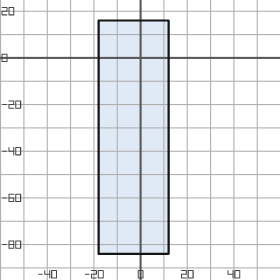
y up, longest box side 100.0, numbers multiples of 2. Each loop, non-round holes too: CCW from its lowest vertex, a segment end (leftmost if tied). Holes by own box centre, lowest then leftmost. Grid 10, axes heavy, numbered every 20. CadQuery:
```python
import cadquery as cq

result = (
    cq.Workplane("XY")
    .moveTo(-18.0, -84.0)
    .lineTo(12.0, -84.0)
    .lineTo(12.0, 16.0)
    .lineTo(-18.0, 16.0)
    .close()
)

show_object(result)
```